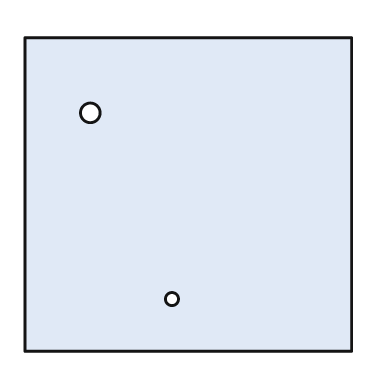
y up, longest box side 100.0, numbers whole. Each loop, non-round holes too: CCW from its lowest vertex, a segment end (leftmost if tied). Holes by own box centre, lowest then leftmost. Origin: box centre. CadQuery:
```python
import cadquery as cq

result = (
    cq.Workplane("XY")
    .moveTo(-50.0, -48.0)
    .lineTo(50.0, -48.0)
    .lineTo(50.0, 48.0)
    .lineTo(-50.0, 48.0)
    .close()
    .moveTo(-5.0, -32.0)
    .circle(2.0)
    .moveTo(-30.0, 25.0)
    .circle(3.0)
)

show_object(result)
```